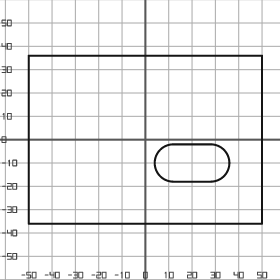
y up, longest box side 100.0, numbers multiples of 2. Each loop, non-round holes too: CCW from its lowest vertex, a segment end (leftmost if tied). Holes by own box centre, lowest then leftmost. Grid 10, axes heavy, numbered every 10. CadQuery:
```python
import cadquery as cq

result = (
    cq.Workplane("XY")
    .moveTo(-50.0, -36.0)
    .lineTo(50.0, -36.0)
    .lineTo(50.0, 36.0)
    .lineTo(-50.0, 36.0)
    .close()
    .moveTo(12.0, -18.0)
    .lineTo(28.0, -18.0)
    .threePointArc((36.0, -10.0), (28.0, -2.0))
    .lineTo(12.0, -2.0)
    .threePointArc((4.0, -10.0), (12.0, -18.0))
    .close()
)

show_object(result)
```